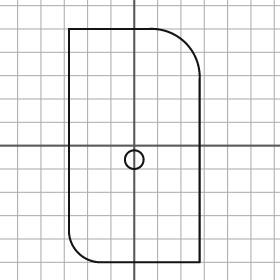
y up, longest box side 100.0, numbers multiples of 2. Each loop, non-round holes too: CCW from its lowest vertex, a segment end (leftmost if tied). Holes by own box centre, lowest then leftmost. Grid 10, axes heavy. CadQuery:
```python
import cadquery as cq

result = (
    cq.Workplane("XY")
    .moveTo(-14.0, -50.0)
    .lineTo(28.0, -50.0)
    .lineTo(28.0, 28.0)
    .threePointArc((22.0, 44.0), (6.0, 50.0))
    .lineTo(-28.0, 50.0)
    .lineTo(-28.0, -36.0)
    .threePointArc((-24.0, -46.0), (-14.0, -50.0))
    .close()
    .moveTo(0.0, -6.0)
    .circle(4.0)
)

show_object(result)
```